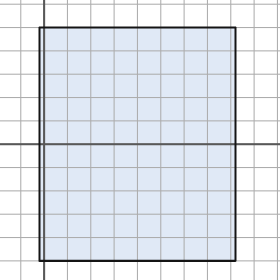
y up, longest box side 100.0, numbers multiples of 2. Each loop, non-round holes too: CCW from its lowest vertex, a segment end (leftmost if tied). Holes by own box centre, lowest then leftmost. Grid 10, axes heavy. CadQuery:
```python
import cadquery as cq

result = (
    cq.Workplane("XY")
    .moveTo(-2.0, -50.0)
    .lineTo(82.0, -50.0)
    .lineTo(82.0, 50.0)
    .lineTo(-2.0, 50.0)
    .close()
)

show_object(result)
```